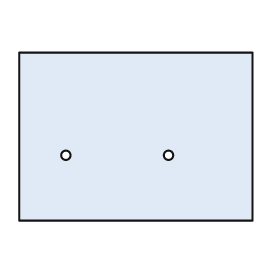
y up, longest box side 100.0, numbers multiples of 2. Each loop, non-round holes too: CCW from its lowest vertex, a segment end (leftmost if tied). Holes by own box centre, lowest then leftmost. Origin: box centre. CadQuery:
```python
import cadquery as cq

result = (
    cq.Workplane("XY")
    .moveTo(-50.0, -36.0)
    .lineTo(50.0, -36.0)
    .lineTo(50.0, 36.0)
    .lineTo(-50.0, 36.0)
    .close()
    .moveTo(-30.0, -8.0)
    .circle(2.0)
    .moveTo(14.0, -8.0)
    .circle(2.0)
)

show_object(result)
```